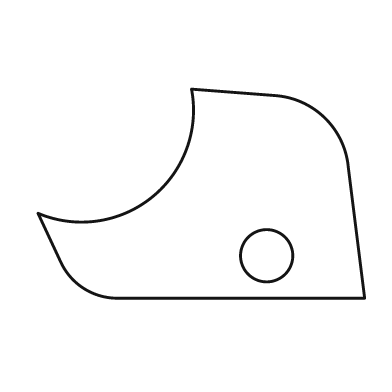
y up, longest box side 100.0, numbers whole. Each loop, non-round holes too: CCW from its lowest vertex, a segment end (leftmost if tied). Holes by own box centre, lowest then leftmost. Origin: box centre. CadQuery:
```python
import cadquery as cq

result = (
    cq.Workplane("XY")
    .moveTo(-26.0, -32.0)
    .lineTo(50.0, -32.0)
    .lineTo(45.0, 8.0)
    .threePointArc((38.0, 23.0), (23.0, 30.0))
    .lineTo(-3.0, 32.0)
    .threePointArc((-15.0, -1.0), (-50.0, -6.0))
    .lineTo(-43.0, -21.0)
    .threePointArc((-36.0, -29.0), (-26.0, -32.0))
    .close()
    .moveTo(20.0, -19.0)
    .circle(8.0)
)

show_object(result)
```